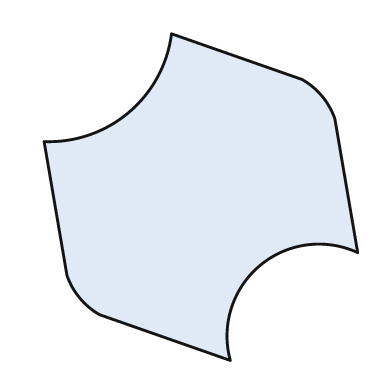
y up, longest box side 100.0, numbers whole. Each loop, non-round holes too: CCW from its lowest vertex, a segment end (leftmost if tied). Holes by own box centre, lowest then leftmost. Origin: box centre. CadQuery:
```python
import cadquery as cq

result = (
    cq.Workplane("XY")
    .moveTo(9.0, -50.0)
    .threePointArc((18.0, -21.0), (48.0, -17.0))
    .lineTo(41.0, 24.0)
    .threePointArc((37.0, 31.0), (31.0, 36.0))
    .lineTo(-9.0, 50.0)
    .threePointArc((-22.0, 26.0), (-48.0, 17.0))
    .lineTo(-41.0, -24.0)
    .threePointArc((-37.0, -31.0), (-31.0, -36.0))
    .close()
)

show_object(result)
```